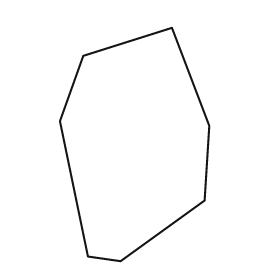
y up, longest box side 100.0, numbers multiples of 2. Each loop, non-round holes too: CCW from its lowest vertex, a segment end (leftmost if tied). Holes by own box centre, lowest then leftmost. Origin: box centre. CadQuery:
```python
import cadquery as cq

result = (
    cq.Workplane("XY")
    .moveTo(-6.0, -50.0)
    .lineTo(30.0, -24.0)
    .lineTo(32.0, 8.0)
    .lineTo(16.0, 50.0)
    .lineTo(-22.0, 38.0)
    .lineTo(-32.0, 10.0)
    .lineTo(-20.0, -48.0)
    .close()
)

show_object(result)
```